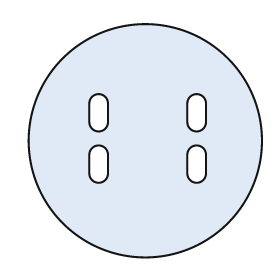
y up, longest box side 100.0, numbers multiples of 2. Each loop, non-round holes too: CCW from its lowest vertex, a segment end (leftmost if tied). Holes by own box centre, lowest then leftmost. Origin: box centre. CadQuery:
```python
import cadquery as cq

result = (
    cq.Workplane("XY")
    .moveTo(0.0, 0.0)
    .circle(50.0)
    .moveTo(-24.0, -14.0)
    .threePointArc((-20.0, -18.0), (-16.0, -14.0))
    .lineTo(-16.0, -6.0)
    .threePointArc((-20.0, -2.0), (-24.0, -6.0))
    .close()
    .moveTo(18.0, -14.0)
    .threePointArc((22.0, -18.0), (26.0, -14.0))
    .lineTo(26.0, -6.0)
    .threePointArc((22.0, -2.0), (18.0, -6.0))
    .close()
    .moveTo(-24.0, 8.0)
    .threePointArc((-20.0, 4.0), (-16.0, 8.0))
    .lineTo(-16.0, 16.0)
    .threePointArc((-20.0, 20.0), (-24.0, 16.0))
    .close()
    .moveTo(18.0, 8.0)
    .threePointArc((22.0, 4.0), (26.0, 8.0))
    .lineTo(26.0, 16.0)
    .threePointArc((22.0, 20.0), (18.0, 16.0))
    .close()
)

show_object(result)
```